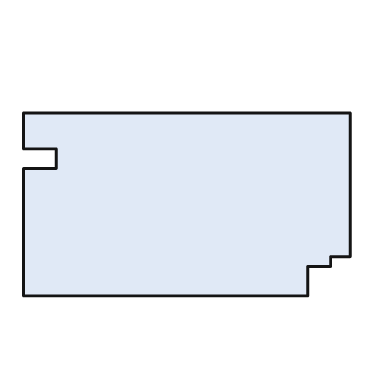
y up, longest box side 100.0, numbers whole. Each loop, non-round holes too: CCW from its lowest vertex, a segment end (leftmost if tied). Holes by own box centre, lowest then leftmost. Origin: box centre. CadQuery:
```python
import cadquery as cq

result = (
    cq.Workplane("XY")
    .moveTo(-50.0, -28.0)
    .lineTo(37.0, -28.0)
    .lineTo(37.0, -19.0)
    .lineTo(44.0, -19.0)
    .lineTo(44.0, -16.0)
    .lineTo(50.0, -16.0)
    .lineTo(50.0, 28.0)
    .lineTo(-50.0, 28.0)
    .lineTo(-50.0, 17.0)
    .lineTo(-40.0, 17.0)
    .lineTo(-40.0, 11.0)
    .lineTo(-50.0, 11.0)
    .close()
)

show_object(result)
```